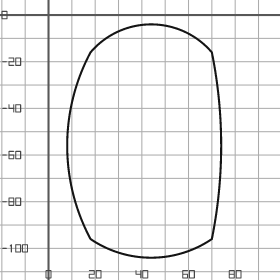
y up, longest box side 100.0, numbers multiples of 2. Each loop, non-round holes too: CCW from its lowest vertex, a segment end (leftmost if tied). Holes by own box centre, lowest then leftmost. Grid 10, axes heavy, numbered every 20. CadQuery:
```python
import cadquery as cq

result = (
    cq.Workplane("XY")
    .moveTo(18.0, -96.0)
    .threePointArc((44.0, -104.0), (70.0, -96.0))
    .threePointArc((74.0, -56.0), (70.0, -16.0))
    .threePointArc((44.0, -4.0), (18.0, -16.0))
    .threePointArc((8.0, -56.0), (18.0, -96.0))
    .close()
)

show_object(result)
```